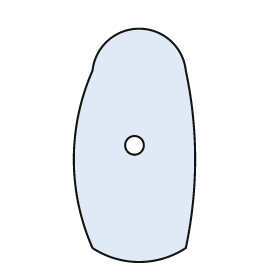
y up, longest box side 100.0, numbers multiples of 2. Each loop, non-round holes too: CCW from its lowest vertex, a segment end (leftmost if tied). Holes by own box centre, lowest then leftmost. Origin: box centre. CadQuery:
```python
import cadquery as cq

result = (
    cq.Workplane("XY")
    .moveTo(-18.0, -44.0)
    .threePointArc((2.0, -50.0), (22.0, -44.0))
    .threePointArc((26.0, -6.0), (22.0, 32.0))
    .threePointArc((2.0, 50.0), (-18.0, 32.0))
    .threePointArc((-26.0, -6.0), (-18.0, -44.0))
    .close()
    .moveTo(0.0, 0.0)
    .circle(4.0)
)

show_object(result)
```